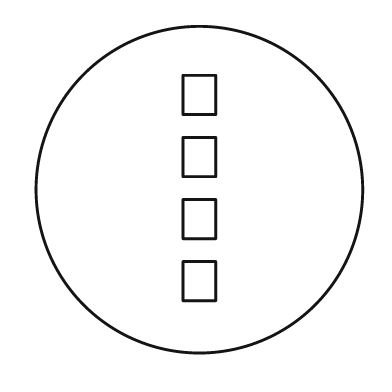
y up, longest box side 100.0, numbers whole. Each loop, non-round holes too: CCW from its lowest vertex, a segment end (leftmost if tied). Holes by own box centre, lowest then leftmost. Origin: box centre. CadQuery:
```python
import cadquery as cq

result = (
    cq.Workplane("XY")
    .moveTo(0.0, 0.0)
    .circle(50.0)
    .moveTo(-5.0, -34.0)
    .lineTo(5.0, -34.0)
    .lineTo(5.0, -22.0)
    .lineTo(-5.0, -22.0)
    .close()
    .moveTo(-5.0, -15.0)
    .lineTo(5.0, -15.0)
    .lineTo(5.0, -3.0)
    .lineTo(-5.0, -3.0)
    .close()
    .moveTo(-5.0, 4.0)
    .lineTo(5.0, 4.0)
    .lineTo(5.0, 16.0)
    .lineTo(-5.0, 16.0)
    .close()
    .moveTo(-5.0, 23.0)
    .lineTo(5.0, 23.0)
    .lineTo(5.0, 35.0)
    .lineTo(-5.0, 35.0)
    .close()
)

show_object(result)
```